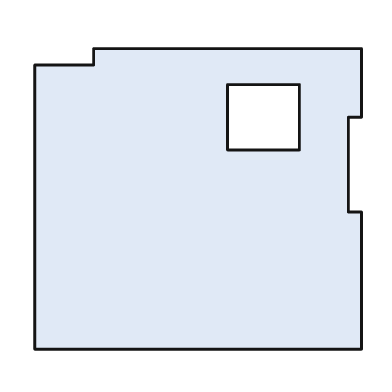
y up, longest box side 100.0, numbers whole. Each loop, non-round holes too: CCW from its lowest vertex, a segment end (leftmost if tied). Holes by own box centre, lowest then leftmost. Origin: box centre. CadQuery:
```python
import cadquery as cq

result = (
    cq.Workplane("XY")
    .moveTo(-50.0, -46.0)
    .lineTo(50.0, -46.0)
    .lineTo(50.0, -4.0)
    .lineTo(46.0, -4.0)
    .lineTo(46.0, 25.0)
    .lineTo(50.0, 25.0)
    .lineTo(50.0, 46.0)
    .lineTo(-32.0, 46.0)
    .lineTo(-32.0, 41.0)
    .lineTo(-50.0, 41.0)
    .close()
    .moveTo(9.0, 15.0)
    .lineTo(31.0, 15.0)
    .lineTo(31.0, 35.0)
    .lineTo(9.0, 35.0)
    .close()
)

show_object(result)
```